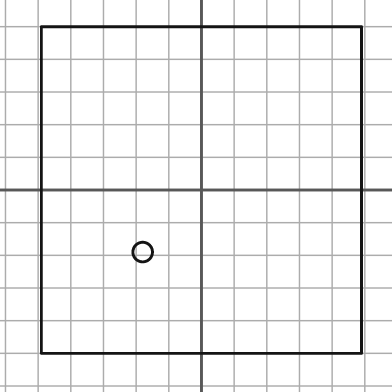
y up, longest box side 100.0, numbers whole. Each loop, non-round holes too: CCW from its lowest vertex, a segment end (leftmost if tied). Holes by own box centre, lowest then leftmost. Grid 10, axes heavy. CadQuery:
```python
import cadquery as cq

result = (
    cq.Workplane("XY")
    .moveTo(-49.0, -50.0)
    .lineTo(49.0, -50.0)
    .lineTo(49.0, 50.0)
    .lineTo(-49.0, 50.0)
    .close()
    .moveTo(-18.0, -19.0)
    .circle(3.0)
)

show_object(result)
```